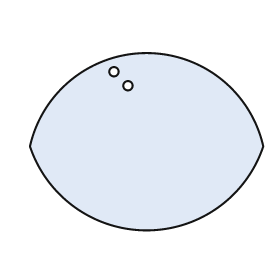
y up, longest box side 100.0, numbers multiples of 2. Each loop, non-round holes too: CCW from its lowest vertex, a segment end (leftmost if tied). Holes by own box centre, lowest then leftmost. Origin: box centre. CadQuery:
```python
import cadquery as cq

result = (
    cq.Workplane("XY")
    .moveTo(-50.0, -2.0)
    .threePointArc((0.0, -38.0), (50.0, -2.0))
    .threePointArc((0.0, 38.0), (-50.0, -2.0))
    .close()
    .moveTo(-8.0, 24.0)
    .circle(2.0)
    .moveTo(-14.0, 30.0)
    .circle(2.0)
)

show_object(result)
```